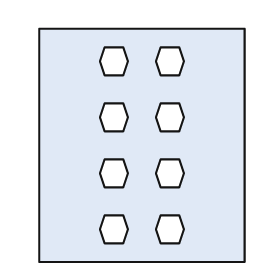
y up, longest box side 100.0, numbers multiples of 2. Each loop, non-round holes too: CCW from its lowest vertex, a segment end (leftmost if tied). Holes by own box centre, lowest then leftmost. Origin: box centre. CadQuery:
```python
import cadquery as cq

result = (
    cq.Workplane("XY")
    .moveTo(-44.0, -50.0)
    .lineTo(44.0, -50.0)
    .lineTo(44.0, 50.0)
    .lineTo(-44.0, 50.0)
    .close()
    .moveTo(-16.0, -42.0)
    .lineTo(-8.0, -42.0)
    .lineTo(-6.0, -36.0)
    .lineTo(-8.0, -30.0)
    .lineTo(-16.0, -30.0)
    .lineTo(-18.0, -36.0)
    .close()
    .moveTo(8.0, -42.0)
    .lineTo(16.0, -42.0)
    .lineTo(18.0, -36.0)
    .lineTo(16.0, -30.0)
    .lineTo(8.0, -30.0)
    .lineTo(6.0, -36.0)
    .close()
    .moveTo(-16.0, -18.0)
    .lineTo(-8.0, -18.0)
    .lineTo(-6.0, -12.0)
    .lineTo(-8.0, -6.0)
    .lineTo(-16.0, -6.0)
    .lineTo(-18.0, -12.0)
    .close()
    .moveTo(8.0, -18.0)
    .lineTo(16.0, -18.0)
    .lineTo(18.0, -12.0)
    .lineTo(16.0, -6.0)
    .lineTo(8.0, -6.0)
    .lineTo(6.0, -12.0)
    .close()
    .moveTo(-16.0, 6.0)
    .lineTo(-8.0, 6.0)
    .lineTo(-6.0, 12.0)
    .lineTo(-8.0, 18.0)
    .lineTo(-16.0, 18.0)
    .lineTo(-18.0, 12.0)
    .close()
    .moveTo(8.0, 6.0)
    .lineTo(16.0, 6.0)
    .lineTo(18.0, 12.0)
    .lineTo(16.0, 18.0)
    .lineTo(8.0, 18.0)
    .lineTo(6.0, 12.0)
    .close()
    .moveTo(-16.0, 30.0)
    .lineTo(-8.0, 30.0)
    .lineTo(-6.0, 36.0)
    .lineTo(-8.0, 42.0)
    .lineTo(-16.0, 42.0)
    .lineTo(-18.0, 36.0)
    .close()
    .moveTo(8.0, 30.0)
    .lineTo(16.0, 30.0)
    .lineTo(18.0, 36.0)
    .lineTo(16.0, 42.0)
    .lineTo(8.0, 42.0)
    .lineTo(6.0, 36.0)
    .close()
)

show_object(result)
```